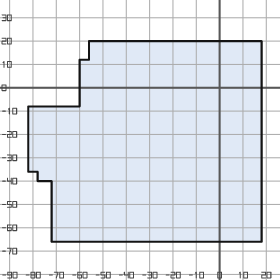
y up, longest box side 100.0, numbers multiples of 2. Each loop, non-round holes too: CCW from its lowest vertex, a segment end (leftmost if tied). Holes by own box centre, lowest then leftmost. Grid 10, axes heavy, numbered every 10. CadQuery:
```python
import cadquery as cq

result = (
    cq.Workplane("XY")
    .moveTo(-72.0, -66.0)
    .lineTo(18.0, -66.0)
    .lineTo(18.0, 20.0)
    .lineTo(-56.0, 20.0)
    .lineTo(-56.0, 12.0)
    .lineTo(-60.0, 12.0)
    .lineTo(-60.0, -8.0)
    .lineTo(-82.0, -8.0)
    .lineTo(-82.0, -36.0)
    .lineTo(-78.0, -36.0)
    .lineTo(-78.0, -40.0)
    .lineTo(-72.0, -40.0)
    .close()
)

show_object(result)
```